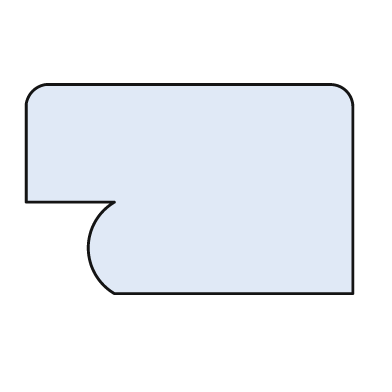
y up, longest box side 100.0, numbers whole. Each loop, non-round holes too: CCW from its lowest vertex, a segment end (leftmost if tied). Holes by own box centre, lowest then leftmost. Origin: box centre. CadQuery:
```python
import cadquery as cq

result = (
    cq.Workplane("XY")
    .moveTo(-23.0, -32.0)
    .lineTo(50.0, -32.0)
    .lineTo(50.0, 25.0)
    .threePointArc((48.0, 30.0), (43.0, 32.0))
    .lineTo(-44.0, 32.0)
    .threePointArc((-48.0, 30.0), (-50.0, 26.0))
    .lineTo(-50.0, -4.0)
    .lineTo(-23.0, -4.0)
    .threePointArc((-31.0, -18.0), (-23.0, -32.0))
    .close()
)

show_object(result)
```